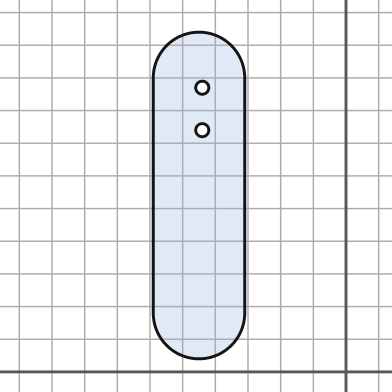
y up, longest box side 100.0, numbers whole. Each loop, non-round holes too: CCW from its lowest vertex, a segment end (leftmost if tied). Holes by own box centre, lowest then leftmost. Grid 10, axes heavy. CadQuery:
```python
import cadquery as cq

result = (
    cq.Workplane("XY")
    .moveTo(-59.0, 18.0)
    .threePointArc((-45.0, 4.0), (-31.0, 18.0))
    .lineTo(-31.0, 90.0)
    .threePointArc((-45.0, 104.0), (-59.0, 90.0))
    .close()
    .moveTo(-44.0, 74.0)
    .circle(2.0)
    .moveTo(-44.0, 87.0)
    .circle(2.0)
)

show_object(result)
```